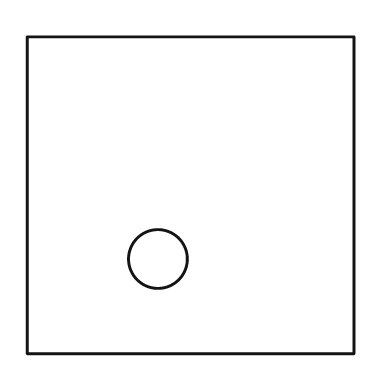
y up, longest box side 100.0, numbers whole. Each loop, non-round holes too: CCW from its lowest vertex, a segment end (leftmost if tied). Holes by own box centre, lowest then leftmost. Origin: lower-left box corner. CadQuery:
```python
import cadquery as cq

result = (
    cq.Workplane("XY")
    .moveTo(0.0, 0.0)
    .lineTo(100.0, 0.0)
    .lineTo(100.0, 97.0)
    .lineTo(0.0, 97.0)
    .close()
    .moveTo(40.0, 29.0)
    .circle(9.0)
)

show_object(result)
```